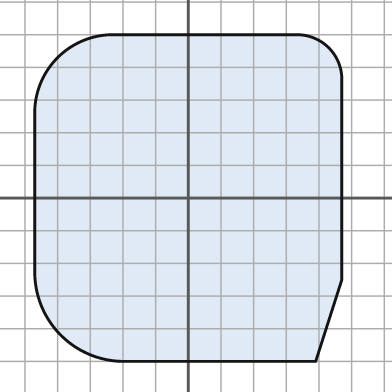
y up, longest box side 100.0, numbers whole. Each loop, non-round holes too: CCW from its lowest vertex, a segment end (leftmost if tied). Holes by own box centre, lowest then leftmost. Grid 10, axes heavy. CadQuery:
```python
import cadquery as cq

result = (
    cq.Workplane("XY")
    .moveTo(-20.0, -50.0)
    .lineTo(39.0, -50.0)
    .lineTo(47.0, -25.0)
    .lineTo(47.0, 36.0)
    .threePointArc((43.0, 46.0), (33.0, 50.0))
    .lineTo(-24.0, 50.0)
    .threePointArc((-40.0, 43.0), (-47.0, 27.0))
    .lineTo(-47.0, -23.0)
    .threePointArc((-39.0, -42.0), (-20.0, -50.0))
    .close()
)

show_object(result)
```